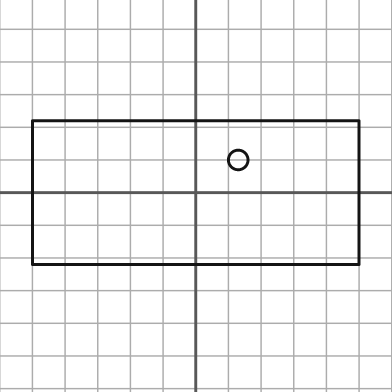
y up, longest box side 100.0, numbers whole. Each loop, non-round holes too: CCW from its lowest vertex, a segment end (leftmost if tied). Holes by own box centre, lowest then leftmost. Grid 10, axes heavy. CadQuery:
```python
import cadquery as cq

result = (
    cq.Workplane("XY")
    .moveTo(-50.0, -22.0)
    .lineTo(50.0, -22.0)
    .lineTo(50.0, 22.0)
    .lineTo(-50.0, 22.0)
    .close()
    .moveTo(13.0, 10.0)
    .circle(3.0)
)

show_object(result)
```